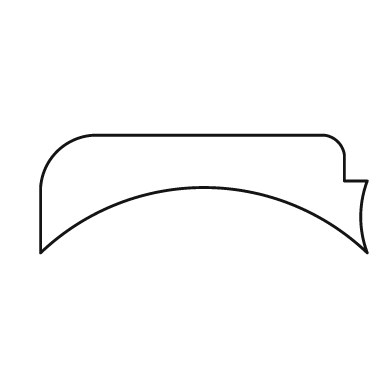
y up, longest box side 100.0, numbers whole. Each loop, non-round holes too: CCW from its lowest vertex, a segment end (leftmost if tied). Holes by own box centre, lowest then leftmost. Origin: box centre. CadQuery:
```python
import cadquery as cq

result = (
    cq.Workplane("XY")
    .moveTo(-50.0, -18.0)
    .threePointArc((0.0, 2.0), (50.0, -18.0))
    .threePointArc((48.0, -7.0), (50.0, 4.0))
    .lineTo(43.0, 4.0)
    .lineTo(43.0, 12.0)
    .threePointArc((41.0, 16.0), (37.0, 18.0))
    .lineTo(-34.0, 18.0)
    .threePointArc((-45.0, 13.0), (-50.0, 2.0))
    .close()
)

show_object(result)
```